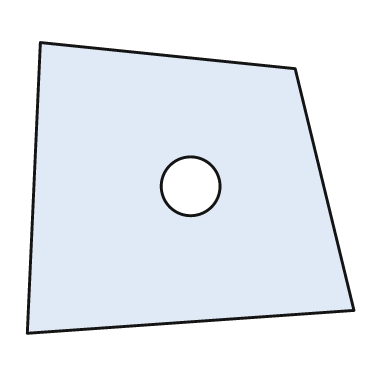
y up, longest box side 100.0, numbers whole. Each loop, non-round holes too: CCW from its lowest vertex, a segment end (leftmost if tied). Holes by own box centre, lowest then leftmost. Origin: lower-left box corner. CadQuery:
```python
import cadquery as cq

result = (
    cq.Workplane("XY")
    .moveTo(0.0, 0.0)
    .lineTo(100.0, 7.0)
    .lineTo(82.0, 81.0)
    .lineTo(4.0, 89.0)
    .close()
    .moveTo(50.0, 45.0)
    .circle(9.0)
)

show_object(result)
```